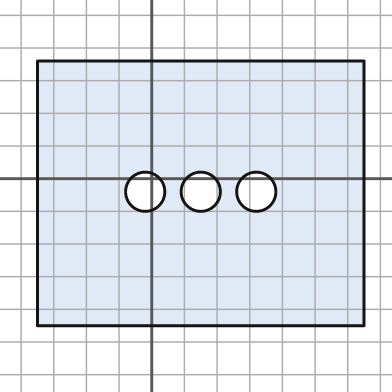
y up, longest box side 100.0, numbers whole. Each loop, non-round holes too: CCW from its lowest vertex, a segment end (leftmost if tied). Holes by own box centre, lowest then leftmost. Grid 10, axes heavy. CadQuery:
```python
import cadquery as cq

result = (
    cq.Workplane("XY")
    .moveTo(-35.0, -45.0)
    .lineTo(65.0, -45.0)
    .lineTo(65.0, 36.0)
    .lineTo(-35.0, 36.0)
    .close()
    .moveTo(-2.0, -4.0)
    .circle(6.0)
    .moveTo(15.0, -4.0)
    .circle(6.0)
    .moveTo(32.0, -4.0)
    .circle(6.0)
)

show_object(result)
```